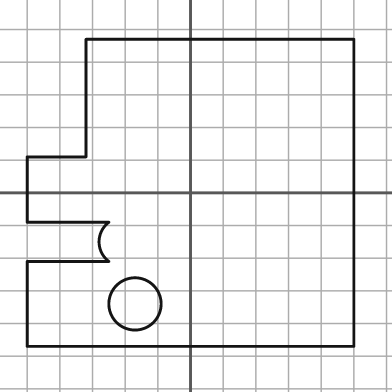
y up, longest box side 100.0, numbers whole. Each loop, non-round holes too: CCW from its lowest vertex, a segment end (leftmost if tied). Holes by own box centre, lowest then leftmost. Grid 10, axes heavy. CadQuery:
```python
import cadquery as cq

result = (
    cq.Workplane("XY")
    .moveTo(-50.0, -47.0)
    .lineTo(50.0, -47.0)
    .lineTo(50.0, 47.0)
    .lineTo(-32.0, 47.0)
    .lineTo(-32.0, 11.0)
    .lineTo(-50.0, 11.0)
    .lineTo(-50.0, -9.0)
    .lineTo(-25.0, -9.0)
    .threePointArc((-28.0, -15.0), (-25.0, -21.0))
    .lineTo(-50.0, -21.0)
    .close()
    .moveTo(-17.0, -34.0)
    .circle(8.0)
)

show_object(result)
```